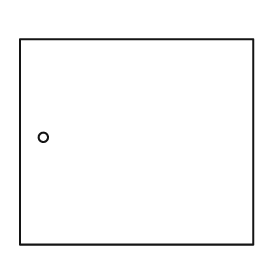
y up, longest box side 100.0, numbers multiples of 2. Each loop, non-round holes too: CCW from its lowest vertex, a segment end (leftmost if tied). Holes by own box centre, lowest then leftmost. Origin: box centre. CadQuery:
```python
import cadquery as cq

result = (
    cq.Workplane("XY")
    .moveTo(-50.0, -44.0)
    .lineTo(50.0, -44.0)
    .lineTo(50.0, 44.0)
    .lineTo(-50.0, 44.0)
    .close()
    .moveTo(-40.0, 2.0)
    .circle(2.0)
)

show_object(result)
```